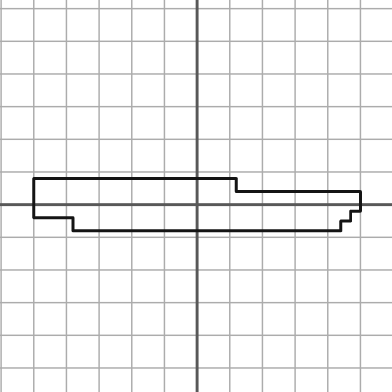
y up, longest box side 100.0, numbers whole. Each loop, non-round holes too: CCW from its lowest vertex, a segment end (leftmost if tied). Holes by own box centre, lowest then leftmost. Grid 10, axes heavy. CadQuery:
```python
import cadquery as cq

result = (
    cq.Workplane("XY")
    .moveTo(-38.0, -8.0)
    .lineTo(44.0, -8.0)
    .lineTo(44.0, -5.0)
    .lineTo(47.0, -5.0)
    .lineTo(47.0, -2.0)
    .lineTo(50.0, -2.0)
    .lineTo(50.0, 4.0)
    .lineTo(12.0, 4.0)
    .lineTo(12.0, 8.0)
    .lineTo(-50.0, 8.0)
    .lineTo(-50.0, -4.0)
    .lineTo(-38.0, -4.0)
    .close()
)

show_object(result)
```